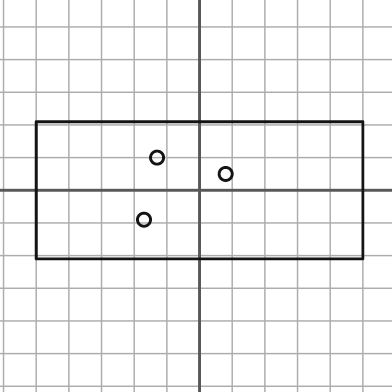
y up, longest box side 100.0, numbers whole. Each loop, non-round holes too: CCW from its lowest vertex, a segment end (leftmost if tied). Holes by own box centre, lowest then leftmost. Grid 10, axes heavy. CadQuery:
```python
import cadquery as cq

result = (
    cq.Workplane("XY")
    .moveTo(-50.0, -21.0)
    .lineTo(50.0, -21.0)
    .lineTo(50.0, 21.0)
    .lineTo(-50.0, 21.0)
    .close()
    .moveTo(-17.0, -9.0)
    .circle(2.0)
    .moveTo(8.0, 5.0)
    .circle(2.0)
    .moveTo(-13.0, 10.0)
    .circle(2.0)
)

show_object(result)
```